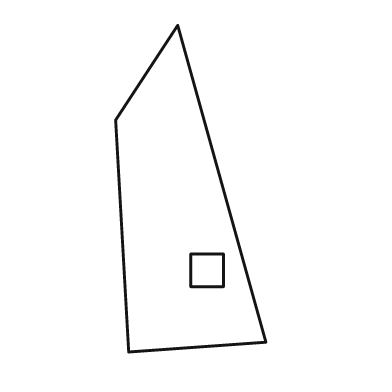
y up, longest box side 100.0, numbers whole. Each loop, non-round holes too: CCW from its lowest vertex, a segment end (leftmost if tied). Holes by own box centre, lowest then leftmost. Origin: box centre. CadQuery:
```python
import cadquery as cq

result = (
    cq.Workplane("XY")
    .moveTo(-19.0, -50.0)
    .lineTo(23.0, -47.0)
    .lineTo(-4.0, 50.0)
    .lineTo(-23.0, 21.0)
    .close()
    .moveTo(0.0, -30.0)
    .lineTo(10.0, -30.0)
    .lineTo(10.0, -20.0)
    .lineTo(0.0, -20.0)
    .close()
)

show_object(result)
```